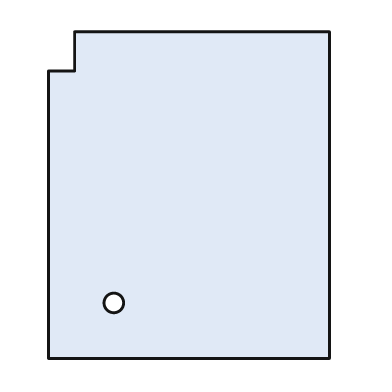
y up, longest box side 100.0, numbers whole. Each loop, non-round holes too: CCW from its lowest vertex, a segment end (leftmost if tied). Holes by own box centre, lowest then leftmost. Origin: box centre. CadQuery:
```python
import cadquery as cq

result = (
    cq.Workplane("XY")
    .moveTo(-43.0, -50.0)
    .lineTo(43.0, -50.0)
    .lineTo(43.0, 50.0)
    .lineTo(-35.0, 50.0)
    .lineTo(-35.0, 38.0)
    .lineTo(-43.0, 38.0)
    .close()
    .moveTo(-23.0, -33.0)
    .circle(3.0)
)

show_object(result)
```